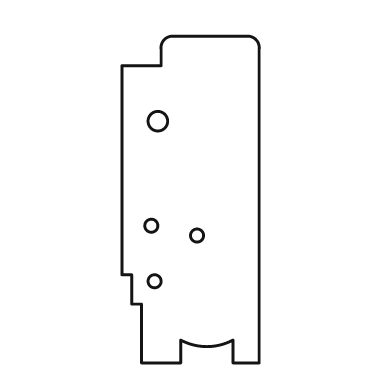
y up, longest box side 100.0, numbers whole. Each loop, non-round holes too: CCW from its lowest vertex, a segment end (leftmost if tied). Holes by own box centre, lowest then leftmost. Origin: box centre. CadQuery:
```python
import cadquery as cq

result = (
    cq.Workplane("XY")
    .moveTo(-15.0, -50.0)
    .lineTo(-3.0, -50.0)
    .lineTo(-3.0, -43.0)
    .threePointArc((5.0, -45.0), (13.0, -43.0))
    .lineTo(13.0, -50.0)
    .lineTo(21.0, -50.0)
    .lineTo(21.0, 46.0)
    .threePointArc((20.0, 49.0), (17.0, 50.0))
    .lineTo(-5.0, 50.0)
    .threePointArc((-8.0, 49.0), (-9.0, 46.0))
    .lineTo(-9.0, 41.0)
    .lineTo(-21.0, 41.0)
    .lineTo(-21.0, -23.0)
    .lineTo(-18.0, -23.0)
    .lineTo(-18.0, -32.0)
    .lineTo(-15.0, -32.0)
    .close()
    .moveTo(-11.0, -25.0)
    .circle(2.0)
    .moveTo(2.0, -11.0)
    .circle(2.0)
    .moveTo(-12.0, -8.0)
    .circle(2.0)
    .moveTo(-10.0, 24.0)
    .circle(3.0)
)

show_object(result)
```